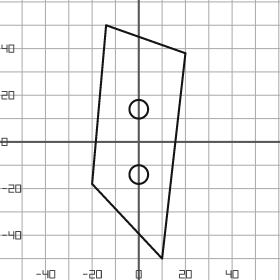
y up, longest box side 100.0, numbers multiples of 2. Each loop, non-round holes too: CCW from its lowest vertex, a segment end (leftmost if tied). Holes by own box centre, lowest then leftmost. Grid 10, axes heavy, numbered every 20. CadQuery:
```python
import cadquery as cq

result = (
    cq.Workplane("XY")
    .moveTo(10.0, -50.0)
    .lineTo(20.0, 38.0)
    .lineTo(-14.0, 50.0)
    .lineTo(-20.0, -18.0)
    .close()
    .moveTo(0.0, -14.0)
    .circle(4.0)
    .moveTo(0.0, 14.0)
    .circle(4.0)
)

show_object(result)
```